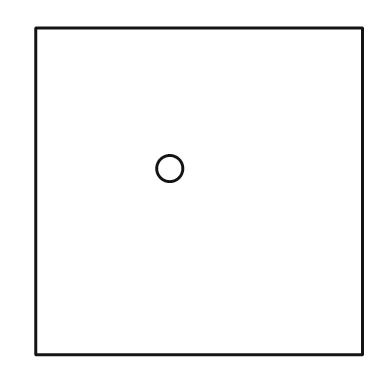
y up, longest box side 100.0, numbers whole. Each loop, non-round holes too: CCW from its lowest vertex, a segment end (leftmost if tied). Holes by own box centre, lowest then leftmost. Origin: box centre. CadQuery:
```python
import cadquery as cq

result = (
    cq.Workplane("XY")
    .moveTo(-50.0, -50.0)
    .lineTo(50.0, -50.0)
    .lineTo(50.0, 50.0)
    .lineTo(-50.0, 50.0)
    .close()
    .moveTo(-9.0, 7.0)
    .circle(4.0)
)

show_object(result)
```